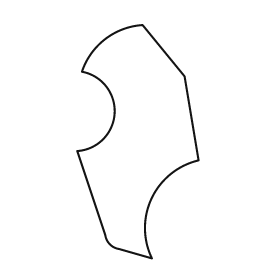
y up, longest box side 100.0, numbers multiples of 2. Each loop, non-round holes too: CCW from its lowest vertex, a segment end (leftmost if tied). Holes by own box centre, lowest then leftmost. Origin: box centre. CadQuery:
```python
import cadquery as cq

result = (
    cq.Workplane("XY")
    .moveTo(6.0, -50.0)
    .threePointArc((6.0, -24.0), (26.0, -8.0))
    .lineTo(20.0, 28.0)
    .lineTo(2.0, 50.0)
    .threePointArc((-14.0, 44.0), (-24.0, 30.0))
    .threePointArc((-10.0, 12.0), (-26.0, -4.0))
    .lineTo(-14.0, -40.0)
    .threePointArc((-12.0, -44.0), (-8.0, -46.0))
    .close()
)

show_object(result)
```